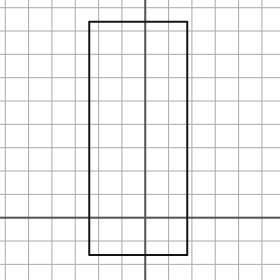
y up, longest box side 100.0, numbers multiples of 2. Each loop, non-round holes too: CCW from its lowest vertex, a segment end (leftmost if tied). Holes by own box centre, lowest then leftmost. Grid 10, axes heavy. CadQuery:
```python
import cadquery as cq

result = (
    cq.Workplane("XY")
    .moveTo(-24.0, -16.0)
    .lineTo(18.0, -16.0)
    .lineTo(18.0, 84.0)
    .lineTo(-24.0, 84.0)
    .close()
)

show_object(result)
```